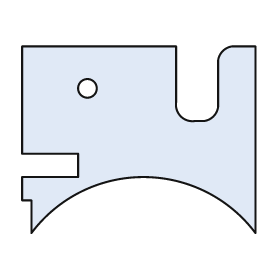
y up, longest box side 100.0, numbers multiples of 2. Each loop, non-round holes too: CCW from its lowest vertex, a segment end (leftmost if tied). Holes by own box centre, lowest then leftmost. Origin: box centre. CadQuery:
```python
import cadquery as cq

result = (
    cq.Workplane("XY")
    .moveTo(-46.0, -40.0)
    .threePointArc((2.0, -16.0), (50.0, -40.0))
    .lineTo(50.0, 40.0)
    .lineTo(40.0, 40.0)
    .threePointArc((36.0, 38.0), (34.0, 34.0))
    .lineTo(34.0, 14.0)
    .threePointArc((32.0, 10.0), (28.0, 8.0))
    .lineTo(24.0, 8.0)
    .threePointArc((18.0, 10.0), (16.0, 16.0))
    .lineTo(16.0, 40.0)
    .lineTo(-50.0, 40.0)
    .lineTo(-50.0, -6.0)
    .lineTo(-26.0, -6.0)
    .lineTo(-26.0, -16.0)
    .lineTo(-50.0, -16.0)
    .lineTo(-50.0, -26.0)
    .lineTo(-46.0, -26.0)
    .close()
    .moveTo(-22.0, 22.0)
    .circle(4.0)
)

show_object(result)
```